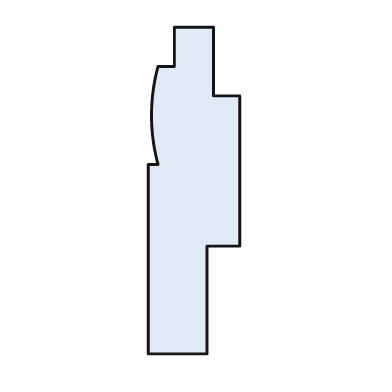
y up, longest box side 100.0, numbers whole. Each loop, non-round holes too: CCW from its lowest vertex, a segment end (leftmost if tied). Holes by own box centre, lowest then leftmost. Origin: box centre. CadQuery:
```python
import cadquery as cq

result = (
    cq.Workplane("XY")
    .moveTo(-14.0, -50.0)
    .lineTo(4.0, -50.0)
    .lineTo(4.0, -17.0)
    .lineTo(14.0, -17.0)
    .lineTo(14.0, 29.0)
    .lineTo(6.0, 29.0)
    .lineTo(6.0, 50.0)
    .lineTo(-6.0, 50.0)
    .lineTo(-6.0, 38.0)
    .lineTo(-11.0, 38.0)
    .threePointArc((-13.0, 23.0), (-11.0, 8.0))
    .lineTo(-14.0, 8.0)
    .close()
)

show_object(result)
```